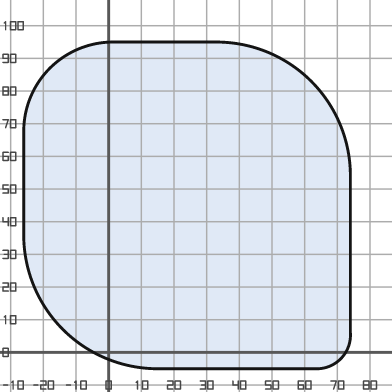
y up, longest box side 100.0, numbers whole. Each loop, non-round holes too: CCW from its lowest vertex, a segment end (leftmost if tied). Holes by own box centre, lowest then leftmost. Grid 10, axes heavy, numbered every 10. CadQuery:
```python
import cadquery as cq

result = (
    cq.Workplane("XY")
    .moveTo(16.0, -5.0)
    .lineTo(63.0, -5.0)
    .threePointArc((71.0, -2.0), (74.0, 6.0))
    .lineTo(74.0, 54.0)
    .threePointArc((62.0, 83.0), (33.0, 95.0))
    .lineTo(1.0, 95.0)
    .threePointArc((-18.0, 87.0), (-26.0, 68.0))
    .lineTo(-26.0, 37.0)
    .threePointArc((-14.0, 7.0), (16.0, -5.0))
    .close()
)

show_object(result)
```